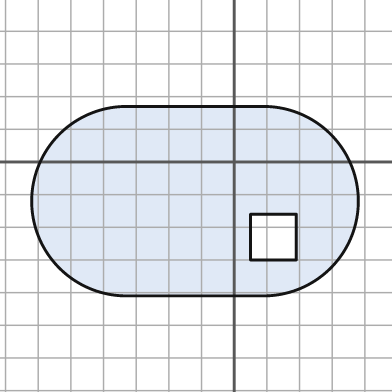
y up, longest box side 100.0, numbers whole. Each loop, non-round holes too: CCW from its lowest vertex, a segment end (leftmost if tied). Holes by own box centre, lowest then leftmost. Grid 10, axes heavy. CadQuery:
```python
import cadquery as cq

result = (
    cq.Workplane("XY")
    .moveTo(-33.0, -41.0)
    .lineTo(9.0, -41.0)
    .threePointArc((38.0, -12.0), (9.0, 17.0))
    .lineTo(-33.0, 17.0)
    .threePointArc((-62.0, -12.0), (-33.0, -41.0))
    .close()
    .moveTo(5.0, -30.0)
    .lineTo(19.0, -30.0)
    .lineTo(19.0, -16.0)
    .lineTo(5.0, -16.0)
    .close()
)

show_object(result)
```